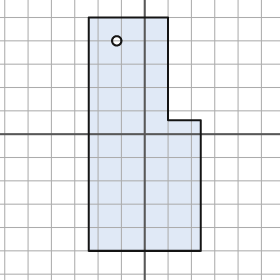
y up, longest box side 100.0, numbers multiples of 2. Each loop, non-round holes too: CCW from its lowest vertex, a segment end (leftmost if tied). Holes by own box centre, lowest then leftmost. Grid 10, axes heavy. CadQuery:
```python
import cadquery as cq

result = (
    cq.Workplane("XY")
    .moveTo(-24.0, -50.0)
    .lineTo(24.0, -50.0)
    .lineTo(24.0, 6.0)
    .lineTo(10.0, 6.0)
    .lineTo(10.0, 50.0)
    .lineTo(-24.0, 50.0)
    .close()
    .moveTo(-12.0, 40.0)
    .circle(2.0)
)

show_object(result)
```